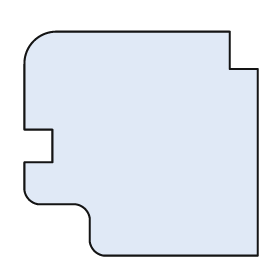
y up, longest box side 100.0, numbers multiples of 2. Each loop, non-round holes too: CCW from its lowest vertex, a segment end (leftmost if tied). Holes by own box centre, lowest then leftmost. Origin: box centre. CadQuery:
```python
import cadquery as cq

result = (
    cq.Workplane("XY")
    .moveTo(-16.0, -48.0)
    .lineTo(50.0, -48.0)
    .lineTo(50.0, 32.0)
    .lineTo(38.0, 32.0)
    .lineTo(38.0, 48.0)
    .lineTo(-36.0, 48.0)
    .threePointArc((-46.0, 44.0), (-50.0, 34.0))
    .lineTo(-50.0, 6.0)
    .lineTo(-38.0, 6.0)
    .lineTo(-38.0, -8.0)
    .lineTo(-50.0, -8.0)
    .lineTo(-50.0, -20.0)
    .threePointArc((-48.0, -24.0), (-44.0, -26.0))
    .lineTo(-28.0, -26.0)
    .threePointArc((-24.0, -28.0), (-22.0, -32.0))
    .lineTo(-22.0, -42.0)
    .threePointArc((-20.0, -46.0), (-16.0, -48.0))
    .close()
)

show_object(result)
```